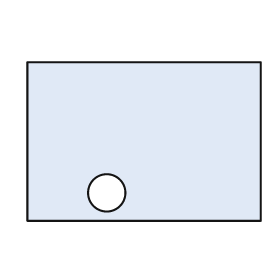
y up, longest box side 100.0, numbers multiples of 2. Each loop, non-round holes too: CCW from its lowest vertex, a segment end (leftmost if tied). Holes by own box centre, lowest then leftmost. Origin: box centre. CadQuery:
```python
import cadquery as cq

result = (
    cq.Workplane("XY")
    .moveTo(-50.0, -34.0)
    .lineTo(50.0, -34.0)
    .lineTo(50.0, 34.0)
    .lineTo(-50.0, 34.0)
    .close()
    .moveTo(-16.0, -22.0)
    .circle(8.0)
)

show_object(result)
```